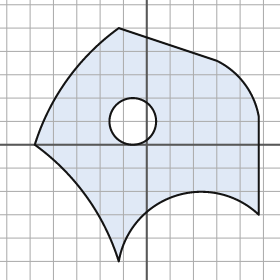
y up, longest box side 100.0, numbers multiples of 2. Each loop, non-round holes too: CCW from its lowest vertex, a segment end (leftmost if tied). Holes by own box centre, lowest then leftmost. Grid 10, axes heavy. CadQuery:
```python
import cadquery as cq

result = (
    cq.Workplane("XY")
    .moveTo(-12.0, -50.0)
    .threePointArc((12.0, -22.0), (48.0, -30.0))
    .lineTo(48.0, 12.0)
    .threePointArc((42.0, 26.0), (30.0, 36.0))
    .lineTo(-12.0, 50.0)
    .threePointArc((-34.0, 28.0), (-48.0, 0.0))
    .threePointArc((-26.0, -22.0), (-12.0, -50.0))
    .close()
    .moveTo(-6.0, 10.0)
    .circle(10.0)
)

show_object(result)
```